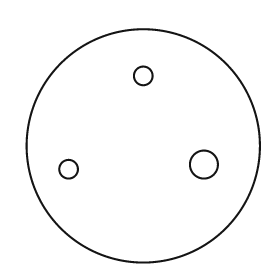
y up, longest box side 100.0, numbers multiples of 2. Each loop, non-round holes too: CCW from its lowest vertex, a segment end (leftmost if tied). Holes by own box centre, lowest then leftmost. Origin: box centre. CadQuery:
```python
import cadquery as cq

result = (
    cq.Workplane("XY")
    .moveTo(0.0, 0.0)
    .circle(50.0)
    .moveTo(-32.0, -10.0)
    .circle(4.0)
    .moveTo(26.0, -8.0)
    .circle(6.0)
    .moveTo(0.0, 30.0)
    .circle(4.0)
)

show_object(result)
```